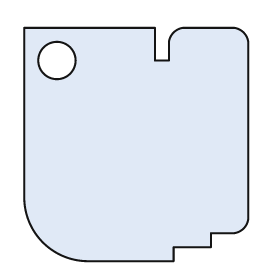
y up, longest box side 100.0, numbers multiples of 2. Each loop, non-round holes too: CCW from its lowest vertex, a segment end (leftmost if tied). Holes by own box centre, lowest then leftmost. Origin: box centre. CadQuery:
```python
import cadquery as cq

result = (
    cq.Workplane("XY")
    .moveTo(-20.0, -50.0)
    .lineTo(16.0, -50.0)
    .lineTo(16.0, -44.0)
    .lineTo(32.0, -44.0)
    .lineTo(32.0, -38.0)
    .lineTo(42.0, -38.0)
    .threePointArc((46.0, -36.0), (48.0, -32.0))
    .lineTo(48.0, 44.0)
    .threePointArc((46.0, 48.0), (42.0, 50.0))
    .lineTo(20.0, 50.0)
    .threePointArc((16.0, 48.0), (14.0, 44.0))
    .lineTo(14.0, 36.0)
    .lineTo(8.0, 36.0)
    .lineTo(8.0, 50.0)
    .lineTo(-48.0, 50.0)
    .lineTo(-48.0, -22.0)
    .threePointArc((-40.0, -42.0), (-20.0, -50.0))
    .close()
    .moveTo(-34.0, 36.0)
    .circle(8.0)
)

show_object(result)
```